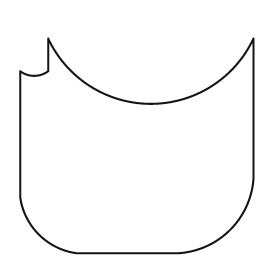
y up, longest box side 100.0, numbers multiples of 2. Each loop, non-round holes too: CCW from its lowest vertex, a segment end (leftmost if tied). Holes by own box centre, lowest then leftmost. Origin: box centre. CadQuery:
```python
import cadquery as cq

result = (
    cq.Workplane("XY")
    .moveTo(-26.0, -46.0)
    .lineTo(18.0, -46.0)
    .threePointArc((40.0, -36.0), (50.0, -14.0))
    .lineTo(50.0, 46.0)
    .threePointArc((6.0, 18.0), (-38.0, 46.0))
    .lineTo(-38.0, 32.0)
    .threePointArc((-44.0, 30.0), (-50.0, 32.0))
    .lineTo(-50.0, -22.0)
    .threePointArc((-42.0, -38.0), (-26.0, -46.0))
    .close()
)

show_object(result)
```